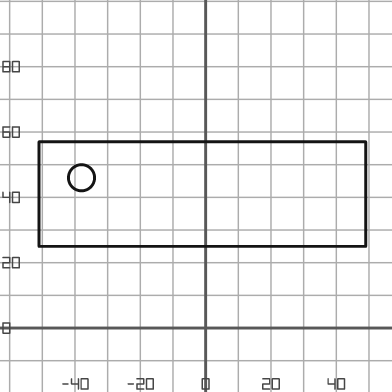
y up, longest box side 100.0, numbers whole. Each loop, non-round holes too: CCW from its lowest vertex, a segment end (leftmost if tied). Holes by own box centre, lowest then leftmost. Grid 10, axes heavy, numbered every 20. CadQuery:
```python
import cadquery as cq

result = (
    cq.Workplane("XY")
    .moveTo(-51.0, 25.0)
    .lineTo(49.0, 25.0)
    .lineTo(49.0, 57.0)
    .lineTo(-51.0, 57.0)
    .close()
    .moveTo(-38.0, 46.0)
    .circle(4.0)
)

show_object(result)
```